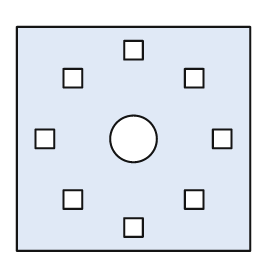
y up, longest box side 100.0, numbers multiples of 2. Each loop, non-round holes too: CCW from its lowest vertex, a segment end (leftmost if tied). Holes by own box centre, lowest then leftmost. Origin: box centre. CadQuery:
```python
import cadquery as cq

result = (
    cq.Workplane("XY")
    .moveTo(-50.0, -48.0)
    .lineTo(50.0, -48.0)
    .lineTo(50.0, 48.0)
    .lineTo(-50.0, 48.0)
    .close()
    .moveTo(-4.0, -42.0)
    .lineTo(4.0, -42.0)
    .lineTo(4.0, -34.0)
    .lineTo(-4.0, -34.0)
    .close()
    .moveTo(-30.0, -30.0)
    .lineTo(-22.0, -30.0)
    .lineTo(-22.0, -22.0)
    .lineTo(-30.0, -22.0)
    .close()
    .moveTo(22.0, -30.0)
    .lineTo(30.0, -30.0)
    .lineTo(30.0, -22.0)
    .lineTo(22.0, -22.0)
    .close()
    .moveTo(-42.0, -4.0)
    .lineTo(-34.0, -4.0)
    .lineTo(-34.0, 4.0)
    .lineTo(-42.0, 4.0)
    .close()
    .moveTo(0.0, 0.0)
    .circle(10.0)
    .moveTo(34.0, -4.0)
    .lineTo(42.0, -4.0)
    .lineTo(42.0, 4.0)
    .lineTo(34.0, 4.0)
    .close()
    .moveTo(-30.0, 22.0)
    .lineTo(-22.0, 22.0)
    .lineTo(-22.0, 30.0)
    .lineTo(-30.0, 30.0)
    .close()
    .moveTo(22.0, 22.0)
    .lineTo(30.0, 22.0)
    .lineTo(30.0, 30.0)
    .lineTo(22.0, 30.0)
    .close()
    .moveTo(-4.0, 34.0)
    .lineTo(4.0, 34.0)
    .lineTo(4.0, 42.0)
    .lineTo(-4.0, 42.0)
    .close()
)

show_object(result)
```